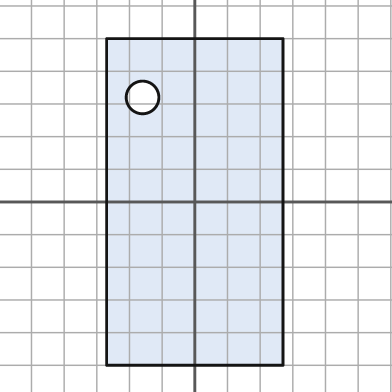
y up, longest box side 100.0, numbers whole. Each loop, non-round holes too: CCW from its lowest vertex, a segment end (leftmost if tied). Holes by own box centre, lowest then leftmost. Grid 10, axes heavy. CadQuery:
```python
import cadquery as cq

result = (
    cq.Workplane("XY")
    .moveTo(-27.0, -50.0)
    .lineTo(27.0, -50.0)
    .lineTo(27.0, 50.0)
    .lineTo(-27.0, 50.0)
    .close()
    .moveTo(-16.0, 32.0)
    .circle(5.0)
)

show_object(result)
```